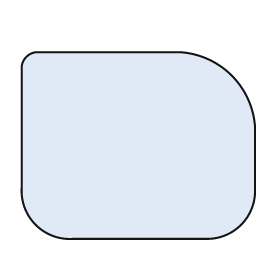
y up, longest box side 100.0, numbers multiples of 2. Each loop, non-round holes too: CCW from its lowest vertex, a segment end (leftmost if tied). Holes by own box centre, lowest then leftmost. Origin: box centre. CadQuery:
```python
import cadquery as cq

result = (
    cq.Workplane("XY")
    .moveTo(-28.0, -40.0)
    .lineTo(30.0, -40.0)
    .threePointArc((44.0, -34.0), (50.0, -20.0))
    .lineTo(50.0, 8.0)
    .threePointArc((40.0, 30.0), (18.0, 40.0))
    .lineTo(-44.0, 40.0)
    .threePointArc((-48.0, 38.0), (-50.0, 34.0))
    .lineTo(-50.0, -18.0)
    .threePointArc((-44.0, -34.0), (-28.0, -40.0))
    .close()
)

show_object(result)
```